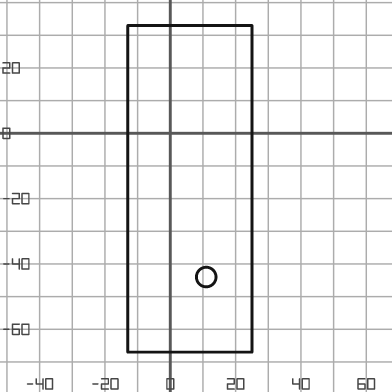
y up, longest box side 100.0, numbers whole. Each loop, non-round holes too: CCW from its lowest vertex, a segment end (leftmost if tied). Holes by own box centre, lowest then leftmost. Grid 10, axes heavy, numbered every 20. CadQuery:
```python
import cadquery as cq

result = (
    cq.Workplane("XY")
    .moveTo(-13.0, -67.0)
    .lineTo(25.0, -67.0)
    .lineTo(25.0, 33.0)
    .lineTo(-13.0, 33.0)
    .close()
    .moveTo(11.0, -44.0)
    .circle(3.0)
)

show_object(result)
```